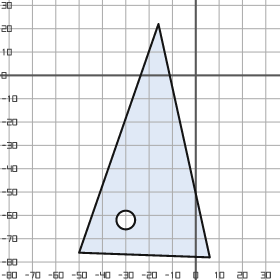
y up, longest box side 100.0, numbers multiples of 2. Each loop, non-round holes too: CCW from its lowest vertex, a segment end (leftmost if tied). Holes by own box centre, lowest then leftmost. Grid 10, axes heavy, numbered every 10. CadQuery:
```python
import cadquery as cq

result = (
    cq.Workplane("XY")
    .moveTo(6.0, -78.0)
    .lineTo(-16.0, 22.0)
    .lineTo(-50.0, -76.0)
    .close()
    .moveTo(-30.0, -62.0)
    .circle(4.0)
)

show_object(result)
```